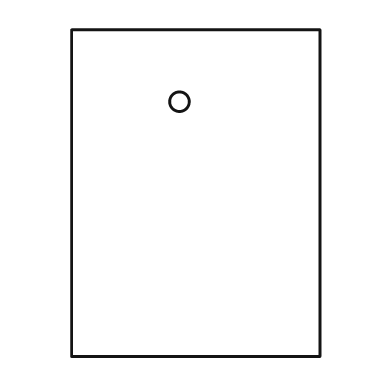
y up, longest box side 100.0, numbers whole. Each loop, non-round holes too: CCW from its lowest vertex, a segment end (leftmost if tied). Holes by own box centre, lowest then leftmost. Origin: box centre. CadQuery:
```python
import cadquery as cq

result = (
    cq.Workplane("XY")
    .moveTo(-38.0, -50.0)
    .lineTo(38.0, -50.0)
    .lineTo(38.0, 50.0)
    .lineTo(-38.0, 50.0)
    .close()
    .moveTo(-5.0, 28.0)
    .circle(3.0)
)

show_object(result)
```